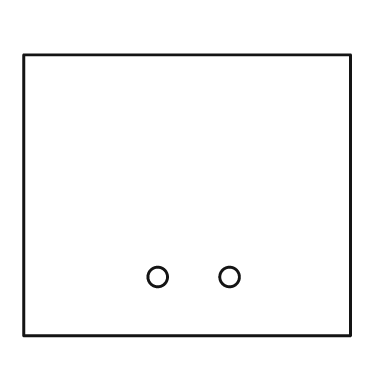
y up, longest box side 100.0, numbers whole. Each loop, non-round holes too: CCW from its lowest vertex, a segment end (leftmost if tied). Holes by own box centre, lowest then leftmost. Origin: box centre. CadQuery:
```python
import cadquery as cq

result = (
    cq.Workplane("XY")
    .moveTo(-50.0, -43.0)
    .lineTo(50.0, -43.0)
    .lineTo(50.0, 43.0)
    .lineTo(-50.0, 43.0)
    .close()
    .moveTo(-9.0, -25.0)
    .circle(3.0)
    .moveTo(13.0, -25.0)
    .circle(3.0)
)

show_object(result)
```